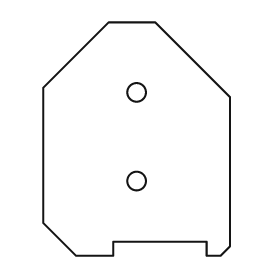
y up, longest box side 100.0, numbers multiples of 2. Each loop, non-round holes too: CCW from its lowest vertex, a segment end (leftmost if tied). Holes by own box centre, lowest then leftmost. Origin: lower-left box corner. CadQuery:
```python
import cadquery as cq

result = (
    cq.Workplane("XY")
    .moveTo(14.0, 0.0)
    .lineTo(30.0, 0.0)
    .lineTo(30.0, 6.0)
    .lineTo(70.0, 6.0)
    .lineTo(70.0, 0.0)
    .lineTo(76.0, 0.0)
    .lineTo(80.0, 4.0)
    .lineTo(80.0, 68.0)
    .lineTo(48.0, 100.0)
    .lineTo(28.0, 100.0)
    .lineTo(0.0, 72.0)
    .lineTo(0.0, 14.0)
    .close()
    .moveTo(40.0, 32.0)
    .circle(4.0)
    .moveTo(40.0, 70.0)
    .circle(4.0)
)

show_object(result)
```